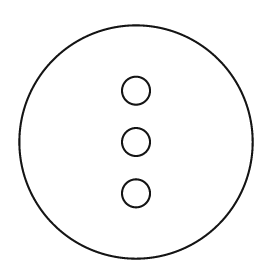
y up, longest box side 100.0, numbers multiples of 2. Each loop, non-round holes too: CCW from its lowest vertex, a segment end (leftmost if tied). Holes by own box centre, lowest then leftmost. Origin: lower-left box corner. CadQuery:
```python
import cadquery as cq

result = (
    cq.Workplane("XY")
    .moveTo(50.0, 50.0)
    .circle(50.0)
    .moveTo(50.0, 28.0)
    .circle(6.0)
    .moveTo(50.0, 50.0)
    .circle(6.0)
    .moveTo(50.0, 72.0)
    .circle(6.0)
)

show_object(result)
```